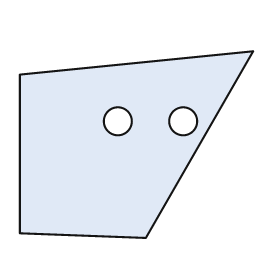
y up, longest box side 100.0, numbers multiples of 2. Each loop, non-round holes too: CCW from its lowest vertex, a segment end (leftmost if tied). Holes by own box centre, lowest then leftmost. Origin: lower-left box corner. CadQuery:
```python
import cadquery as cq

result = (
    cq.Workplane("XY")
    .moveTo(54.0, 0.0)
    .lineTo(100.0, 80.0)
    .lineTo(0.0, 70.0)
    .lineTo(0.0, 2.0)
    .close()
    .moveTo(42.0, 50.0)
    .circle(6.0)
    .moveTo(70.0, 50.0)
    .circle(6.0)
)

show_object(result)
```